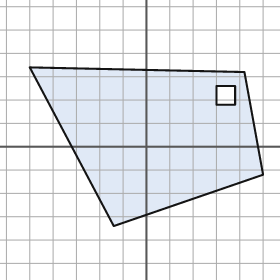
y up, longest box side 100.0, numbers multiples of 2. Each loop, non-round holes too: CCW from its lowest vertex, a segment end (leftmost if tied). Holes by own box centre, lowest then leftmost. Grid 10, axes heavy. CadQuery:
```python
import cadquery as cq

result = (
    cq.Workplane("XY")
    .moveTo(-14.0, -34.0)
    .lineTo(50.0, -12.0)
    .lineTo(42.0, 32.0)
    .lineTo(-50.0, 34.0)
    .close()
    .moveTo(30.0, 18.0)
    .lineTo(38.0, 18.0)
    .lineTo(38.0, 26.0)
    .lineTo(30.0, 26.0)
    .close()
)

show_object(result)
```